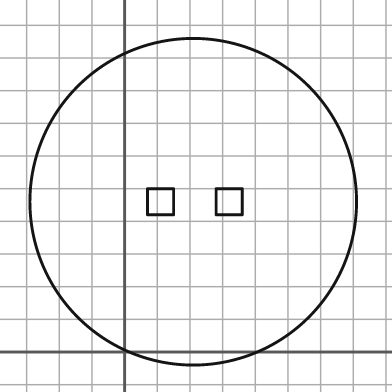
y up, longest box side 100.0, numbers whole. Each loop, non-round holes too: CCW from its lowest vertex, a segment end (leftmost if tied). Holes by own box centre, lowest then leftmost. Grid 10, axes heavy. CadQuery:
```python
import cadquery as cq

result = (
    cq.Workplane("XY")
    .moveTo(21.0, 46.0)
    .circle(50.0)
    .moveTo(7.0, 42.0)
    .lineTo(15.0, 42.0)
    .lineTo(15.0, 50.0)
    .lineTo(7.0, 50.0)
    .close()
    .moveTo(28.0, 42.0)
    .lineTo(36.0, 42.0)
    .lineTo(36.0, 50.0)
    .lineTo(28.0, 50.0)
    .close()
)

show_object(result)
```